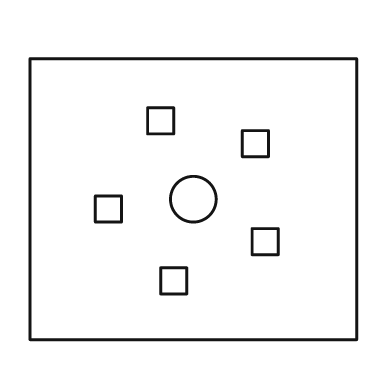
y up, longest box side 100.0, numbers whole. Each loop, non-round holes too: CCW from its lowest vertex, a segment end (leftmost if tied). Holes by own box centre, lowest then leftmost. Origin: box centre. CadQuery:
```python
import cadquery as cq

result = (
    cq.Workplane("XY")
    .moveTo(-50.0, -43.0)
    .lineTo(50.0, -43.0)
    .lineTo(50.0, 43.0)
    .lineTo(-50.0, 43.0)
    .close()
    .moveTo(-10.0, -29.0)
    .lineTo(-2.0, -29.0)
    .lineTo(-2.0, -21.0)
    .lineTo(-10.0, -21.0)
    .close()
    .moveTo(18.0, -17.0)
    .lineTo(26.0, -17.0)
    .lineTo(26.0, -9.0)
    .lineTo(18.0, -9.0)
    .close()
    .moveTo(-30.0, -7.0)
    .lineTo(-22.0, -7.0)
    .lineTo(-22.0, 1.0)
    .lineTo(-30.0, 1.0)
    .close()
    .moveTo(0.0, 0.0)
    .circle(7.0)
    .moveTo(15.0, 13.0)
    .lineTo(23.0, 13.0)
    .lineTo(23.0, 21.0)
    .lineTo(15.0, 21.0)
    .close()
    .moveTo(-14.0, 20.0)
    .lineTo(-6.0, 20.0)
    .lineTo(-6.0, 28.0)
    .lineTo(-14.0, 28.0)
    .close()
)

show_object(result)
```